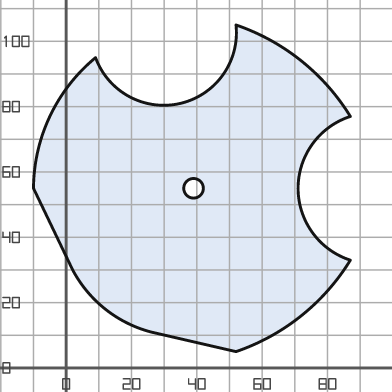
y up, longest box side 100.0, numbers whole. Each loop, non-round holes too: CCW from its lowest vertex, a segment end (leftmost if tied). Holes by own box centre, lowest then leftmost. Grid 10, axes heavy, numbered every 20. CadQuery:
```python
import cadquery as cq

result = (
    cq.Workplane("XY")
    .moveTo(52.0, 5.0)
    .threePointArc((72.0, 16.0), (87.0, 33.0))
    .threePointArc((71.0, 55.0), (87.0, 77.0))
    .threePointArc((72.0, 94.0), (52.0, 105.0))
    .threePointArc((35.0, 81.0), (9.0, 95.0))
    .threePointArc((-5.0, 77.0), (-10.0, 55.0))
    .lineTo(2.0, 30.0)
    .threePointArc((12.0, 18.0), (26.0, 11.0))
    .close()
    .moveTo(39.0, 55.0)
    .circle(3.0)
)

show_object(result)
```